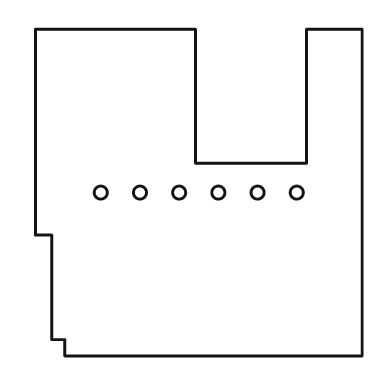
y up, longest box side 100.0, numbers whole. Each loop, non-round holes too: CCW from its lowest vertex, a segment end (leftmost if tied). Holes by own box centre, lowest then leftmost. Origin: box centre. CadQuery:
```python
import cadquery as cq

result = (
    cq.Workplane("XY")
    .moveTo(-41.0, -50.0)
    .lineTo(50.0, -50.0)
    .lineTo(50.0, 50.0)
    .lineTo(33.0, 50.0)
    .lineTo(33.0, 9.0)
    .lineTo(-1.0, 9.0)
    .lineTo(-1.0, 50.0)
    .lineTo(-50.0, 50.0)
    .lineTo(-50.0, -13.0)
    .lineTo(-45.0, -13.0)
    .lineTo(-45.0, -45.0)
    .lineTo(-41.0, -45.0)
    .close()
    .moveTo(-30.0, 0.0)
    .circle(2.0)
    .moveTo(-18.0, 0.0)
    .circle(2.0)
    .moveTo(-6.0, 0.0)
    .circle(2.0)
    .moveTo(6.0, 0.0)
    .circle(2.0)
    .moveTo(18.0, 0.0)
    .circle(2.0)
    .moveTo(30.0, 0.0)
    .circle(2.0)
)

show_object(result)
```